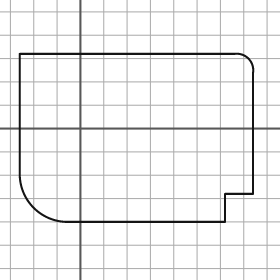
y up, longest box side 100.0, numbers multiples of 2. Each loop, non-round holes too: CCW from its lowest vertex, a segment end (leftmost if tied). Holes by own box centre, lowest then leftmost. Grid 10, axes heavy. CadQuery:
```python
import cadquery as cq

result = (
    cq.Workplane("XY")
    .moveTo(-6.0, -40.0)
    .lineTo(62.0, -40.0)
    .lineTo(62.0, -28.0)
    .lineTo(74.0, -28.0)
    .lineTo(74.0, 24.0)
    .threePointArc((72.0, 30.0), (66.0, 32.0))
    .lineTo(-26.0, 32.0)
    .lineTo(-26.0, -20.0)
    .threePointArc((-20.0, -34.0), (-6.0, -40.0))
    .close()
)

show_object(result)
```